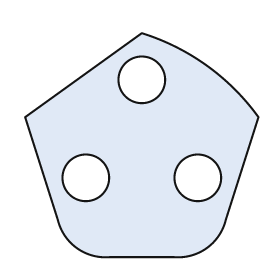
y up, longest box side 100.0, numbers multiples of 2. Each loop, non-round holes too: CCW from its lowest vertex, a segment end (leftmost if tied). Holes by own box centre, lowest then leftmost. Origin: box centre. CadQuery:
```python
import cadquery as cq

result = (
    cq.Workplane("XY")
    .moveTo(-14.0, -48.0)
    .lineTo(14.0, -48.0)
    .threePointArc((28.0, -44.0), (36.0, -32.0))
    .lineTo(50.0, 12.0)
    .threePointArc((28.0, 34.0), (0.0, 48.0))
    .lineTo(-50.0, 12.0)
    .lineTo(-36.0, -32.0)
    .threePointArc((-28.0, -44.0), (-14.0, -48.0))
    .close()
    .moveTo(-24.0, -14.0)
    .circle(10.0)
    .moveTo(24.0, -14.0)
    .circle(10.0)
    .moveTo(0.0, 28.0)
    .circle(10.0)
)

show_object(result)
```